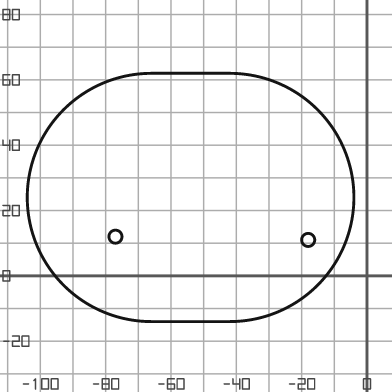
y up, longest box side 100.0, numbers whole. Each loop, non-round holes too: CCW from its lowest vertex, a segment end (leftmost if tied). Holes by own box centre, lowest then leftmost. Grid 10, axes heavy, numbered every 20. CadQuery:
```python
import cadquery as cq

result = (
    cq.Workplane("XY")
    .moveTo(-66.0, -14.0)
    .lineTo(-42.0, -14.0)
    .threePointArc((-4.0, 24.0), (-42.0, 62.0))
    .lineTo(-66.0, 62.0)
    .threePointArc((-104.0, 24.0), (-66.0, -14.0))
    .close()
    .moveTo(-18.0, 11.0)
    .circle(2.0)
    .moveTo(-77.0, 12.0)
    .circle(2.0)
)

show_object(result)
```